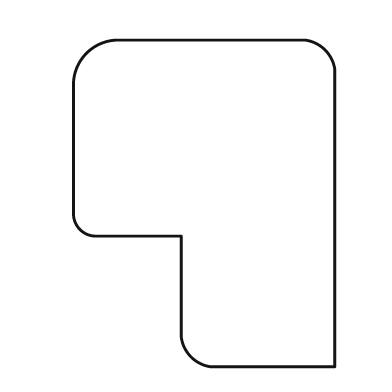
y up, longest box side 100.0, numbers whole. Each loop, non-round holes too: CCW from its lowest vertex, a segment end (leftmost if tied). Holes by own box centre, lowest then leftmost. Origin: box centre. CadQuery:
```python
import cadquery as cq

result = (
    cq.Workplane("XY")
    .moveTo(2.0, -50.0)
    .lineTo(40.0, -50.0)
    .lineTo(40.0, 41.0)
    .threePointArc((37.0, 47.0), (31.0, 50.0))
    .lineTo(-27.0, 50.0)
    .threePointArc((-36.0, 46.0), (-40.0, 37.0))
    .lineTo(-40.0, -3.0)
    .threePointArc((-38.0, -8.0), (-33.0, -10.0))
    .lineTo(-7.0, -10.0)
    .lineTo(-7.0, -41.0)
    .threePointArc((-4.0, -47.0), (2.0, -50.0))
    .close()
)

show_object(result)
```